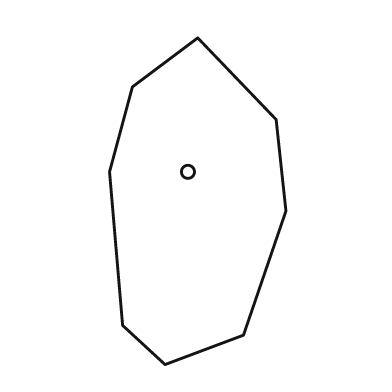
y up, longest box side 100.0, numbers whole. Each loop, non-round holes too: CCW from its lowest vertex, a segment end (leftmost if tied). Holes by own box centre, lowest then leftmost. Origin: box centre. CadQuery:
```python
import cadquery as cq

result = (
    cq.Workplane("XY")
    .moveTo(-10.0, -50.0)
    .lineTo(14.0, -41.0)
    .lineTo(27.0, -3.0)
    .lineTo(24.0, 25.0)
    .lineTo(0.0, 50.0)
    .lineTo(-20.0, 35.0)
    .lineTo(-27.0, 9.0)
    .lineTo(-23.0, -38.0)
    .close()
    .moveTo(-3.0, 9.0)
    .circle(2.0)
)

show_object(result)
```